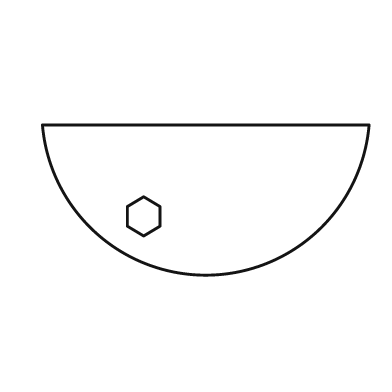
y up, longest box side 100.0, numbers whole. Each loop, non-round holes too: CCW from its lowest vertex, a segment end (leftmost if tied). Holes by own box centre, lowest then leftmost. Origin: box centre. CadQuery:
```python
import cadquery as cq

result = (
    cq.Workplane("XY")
    .moveTo(-50.0, 23.0)
    .threePointArc((0.0, -23.0), (50.0, 23.0))
    .close()
    .moveTo(-19.0, -11.0)
    .lineTo(-14.0, -8.0)
    .lineTo(-14.0, -2.0)
    .lineTo(-19.0, 1.0)
    .lineTo(-24.0, -2.0)
    .lineTo(-24.0, -8.0)
    .close()
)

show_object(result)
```